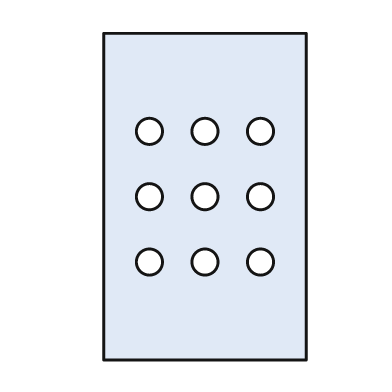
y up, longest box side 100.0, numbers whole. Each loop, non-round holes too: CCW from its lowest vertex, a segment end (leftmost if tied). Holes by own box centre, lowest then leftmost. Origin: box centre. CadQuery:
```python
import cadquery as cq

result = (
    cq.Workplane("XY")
    .moveTo(-31.0, -50.0)
    .lineTo(31.0, -50.0)
    .lineTo(31.0, 50.0)
    .lineTo(-31.0, 50.0)
    .close()
    .moveTo(-17.0, -20.0)
    .circle(4.0)
    .moveTo(0.0, -20.0)
    .circle(4.0)
    .moveTo(17.0, -20.0)
    .circle(4.0)
    .moveTo(-17.0, 0.0)
    .circle(4.0)
    .moveTo(0.0, 0.0)
    .circle(4.0)
    .moveTo(17.0, 0.0)
    .circle(4.0)
    .moveTo(-17.0, 20.0)
    .circle(4.0)
    .moveTo(0.0, 20.0)
    .circle(4.0)
    .moveTo(17.0, 20.0)
    .circle(4.0)
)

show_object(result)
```